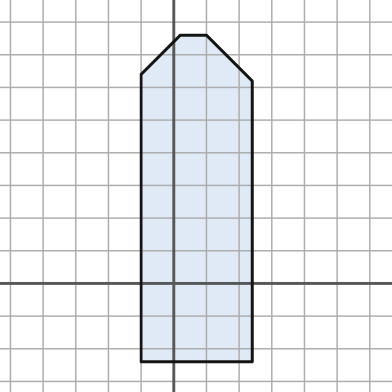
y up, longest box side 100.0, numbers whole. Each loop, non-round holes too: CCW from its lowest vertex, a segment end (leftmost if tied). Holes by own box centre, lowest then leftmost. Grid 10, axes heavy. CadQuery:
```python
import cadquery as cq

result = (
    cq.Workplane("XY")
    .moveTo(-10.0, -24.0)
    .lineTo(24.0, -24.0)
    .lineTo(24.0, 62.0)
    .lineTo(10.0, 76.0)
    .lineTo(2.0, 76.0)
    .lineTo(-10.0, 64.0)
    .close()
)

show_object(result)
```